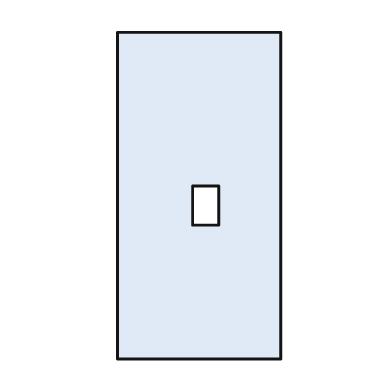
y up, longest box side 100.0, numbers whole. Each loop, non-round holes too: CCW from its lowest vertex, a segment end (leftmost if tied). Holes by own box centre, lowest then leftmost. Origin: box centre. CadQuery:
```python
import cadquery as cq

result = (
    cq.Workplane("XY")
    .moveTo(-25.0, -50.0)
    .lineTo(25.0, -50.0)
    .lineTo(25.0, 50.0)
    .lineTo(-25.0, 50.0)
    .close()
    .moveTo(-2.0, -9.0)
    .lineTo(6.0, -9.0)
    .lineTo(6.0, 3.0)
    .lineTo(-2.0, 3.0)
    .close()
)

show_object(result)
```